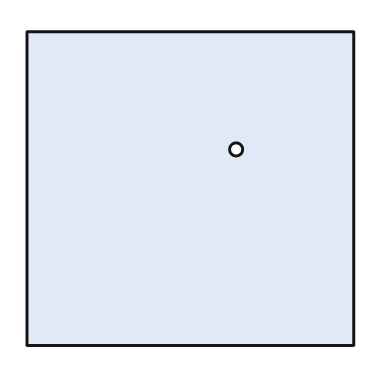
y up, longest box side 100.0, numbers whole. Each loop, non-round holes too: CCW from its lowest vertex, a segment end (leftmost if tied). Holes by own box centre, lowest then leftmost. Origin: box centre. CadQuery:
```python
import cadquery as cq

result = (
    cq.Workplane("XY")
    .moveTo(-50.0, -48.0)
    .lineTo(50.0, -48.0)
    .lineTo(50.0, 48.0)
    .lineTo(-50.0, 48.0)
    .close()
    .moveTo(14.0, 12.0)
    .circle(2.0)
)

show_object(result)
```